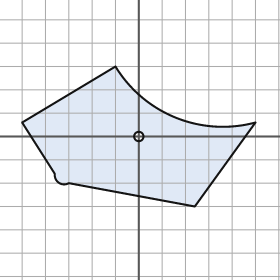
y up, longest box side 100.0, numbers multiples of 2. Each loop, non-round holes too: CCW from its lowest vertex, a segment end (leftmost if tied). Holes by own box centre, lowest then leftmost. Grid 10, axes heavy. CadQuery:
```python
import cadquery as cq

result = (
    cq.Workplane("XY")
    .moveTo(24.0, -30.0)
    .lineTo(50.0, 6.0)
    .threePointArc((16.0, 8.0), (-10.0, 30.0))
    .lineTo(-50.0, 6.0)
    .lineTo(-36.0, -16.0)
    .threePointArc((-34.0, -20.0), (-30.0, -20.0))
    .close()
    .moveTo(0.0, 0.0)
    .circle(2.0)
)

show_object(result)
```